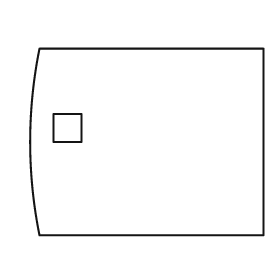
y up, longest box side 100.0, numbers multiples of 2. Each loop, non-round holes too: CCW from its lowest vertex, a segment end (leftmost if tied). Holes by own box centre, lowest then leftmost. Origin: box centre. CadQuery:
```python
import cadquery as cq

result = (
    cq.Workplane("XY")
    .moveTo(-46.0, -40.0)
    .lineTo(50.0, -40.0)
    .lineTo(50.0, 40.0)
    .lineTo(-46.0, 40.0)
    .threePointArc((-50.0, 0.0), (-46.0, -40.0))
    .close()
    .moveTo(-40.0, 0.0)
    .lineTo(-28.0, 0.0)
    .lineTo(-28.0, 12.0)
    .lineTo(-40.0, 12.0)
    .close()
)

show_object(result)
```